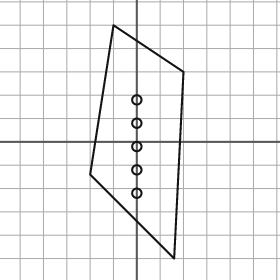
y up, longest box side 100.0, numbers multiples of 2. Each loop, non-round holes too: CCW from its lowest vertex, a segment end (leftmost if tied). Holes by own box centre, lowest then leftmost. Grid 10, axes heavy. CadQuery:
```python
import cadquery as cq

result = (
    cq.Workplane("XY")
    .moveTo(16.0, -50.0)
    .lineTo(20.0, 30.0)
    .lineTo(-10.0, 50.0)
    .lineTo(-20.0, -14.0)
    .close()
    .moveTo(0.0, -22.0)
    .circle(2.0)
    .moveTo(0.0, -12.0)
    .circle(2.0)
    .moveTo(0.0, -2.0)
    .circle(2.0)
    .moveTo(0.0, 8.0)
    .circle(2.0)
    .moveTo(0.0, 18.0)
    .circle(2.0)
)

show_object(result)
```